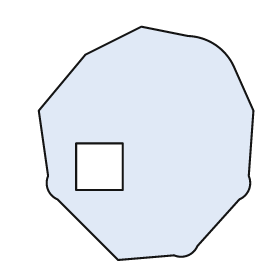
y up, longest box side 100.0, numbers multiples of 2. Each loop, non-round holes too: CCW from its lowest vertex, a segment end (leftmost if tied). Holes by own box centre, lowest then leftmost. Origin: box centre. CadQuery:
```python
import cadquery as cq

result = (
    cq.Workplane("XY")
    .moveTo(-12.0, -50.0)
    .lineTo(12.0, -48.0)
    .threePointArc((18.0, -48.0), (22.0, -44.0))
    .lineTo(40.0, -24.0)
    .threePointArc((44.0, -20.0), (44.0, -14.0))
    .lineTo(46.0, 14.0)
    .lineTo(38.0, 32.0)
    .threePointArc((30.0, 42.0), (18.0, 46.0))
    .lineTo(-2.0, 50.0)
    .lineTo(-26.0, 38.0)
    .lineTo(-46.0, 14.0)
    .lineTo(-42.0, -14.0)
    .threePointArc((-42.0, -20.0), (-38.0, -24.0))
    .close()
    .moveTo(-30.0, -20.0)
    .lineTo(-10.0, -20.0)
    .lineTo(-10.0, 0.0)
    .lineTo(-30.0, 0.0)
    .close()
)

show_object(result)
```